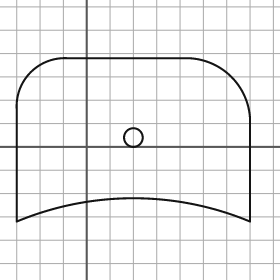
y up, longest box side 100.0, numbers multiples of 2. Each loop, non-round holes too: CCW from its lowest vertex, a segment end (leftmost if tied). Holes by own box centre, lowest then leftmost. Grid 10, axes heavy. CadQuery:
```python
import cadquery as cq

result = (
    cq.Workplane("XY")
    .moveTo(-30.0, -32.0)
    .threePointArc((20.0, -22.0), (70.0, -32.0))
    .lineTo(70.0, 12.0)
    .threePointArc((62.0, 30.0), (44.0, 38.0))
    .lineTo(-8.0, 38.0)
    .threePointArc((-24.0, 32.0), (-30.0, 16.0))
    .close()
    .moveTo(20.0, 4.0)
    .circle(4.0)
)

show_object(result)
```